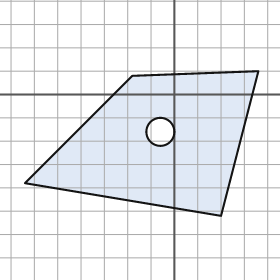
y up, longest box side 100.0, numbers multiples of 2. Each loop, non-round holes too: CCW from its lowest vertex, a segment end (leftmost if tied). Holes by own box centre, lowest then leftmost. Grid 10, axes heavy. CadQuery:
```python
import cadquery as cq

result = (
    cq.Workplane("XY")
    .moveTo(20.0, -52.0)
    .lineTo(36.0, 10.0)
    .lineTo(-18.0, 8.0)
    .lineTo(-64.0, -38.0)
    .close()
    .moveTo(-6.0, -16.0)
    .circle(6.0)
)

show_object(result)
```